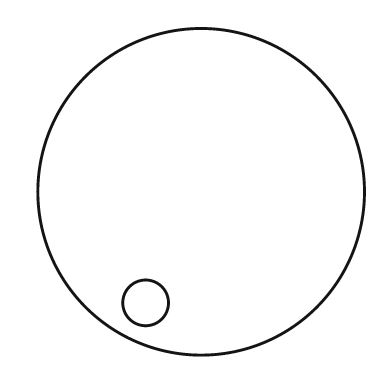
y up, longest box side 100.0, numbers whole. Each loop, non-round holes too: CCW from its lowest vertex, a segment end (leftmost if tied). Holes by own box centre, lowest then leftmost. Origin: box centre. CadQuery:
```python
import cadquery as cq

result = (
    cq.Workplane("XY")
    .moveTo(0.0, 0.0)
    .circle(50.0)
    .moveTo(-17.0, -34.0)
    .circle(7.0)
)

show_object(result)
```